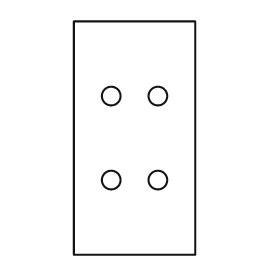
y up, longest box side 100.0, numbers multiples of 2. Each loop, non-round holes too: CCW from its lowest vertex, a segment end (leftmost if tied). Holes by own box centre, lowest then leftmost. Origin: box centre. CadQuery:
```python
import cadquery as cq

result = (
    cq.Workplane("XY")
    .moveTo(-26.0, -50.0)
    .lineTo(26.0, -50.0)
    .lineTo(26.0, 50.0)
    .lineTo(-26.0, 50.0)
    .close()
    .moveTo(-10.0, -18.0)
    .circle(4.0)
    .moveTo(10.0, -18.0)
    .circle(4.0)
    .moveTo(-10.0, 18.0)
    .circle(4.0)
    .moveTo(10.0, 18.0)
    .circle(4.0)
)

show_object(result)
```